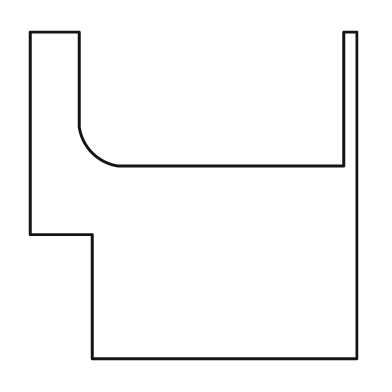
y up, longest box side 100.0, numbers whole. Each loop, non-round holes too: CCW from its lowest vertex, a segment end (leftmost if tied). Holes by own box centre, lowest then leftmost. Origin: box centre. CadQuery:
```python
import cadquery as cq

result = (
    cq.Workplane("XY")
    .moveTo(-31.0, -50.0)
    .lineTo(50.0, -50.0)
    .lineTo(50.0, 50.0)
    .lineTo(46.0, 50.0)
    .lineTo(46.0, 9.0)
    .lineTo(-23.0, 9.0)
    .threePointArc((-31.0, 13.0), (-35.0, 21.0))
    .lineTo(-35.0, 50.0)
    .lineTo(-50.0, 50.0)
    .lineTo(-50.0, -12.0)
    .lineTo(-31.0, -12.0)
    .close()
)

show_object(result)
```